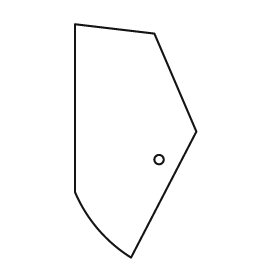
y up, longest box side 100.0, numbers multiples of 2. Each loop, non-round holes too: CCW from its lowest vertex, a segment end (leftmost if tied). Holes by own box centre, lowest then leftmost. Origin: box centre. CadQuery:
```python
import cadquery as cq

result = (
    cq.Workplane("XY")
    .moveTo(-2.0, -50.0)
    .lineTo(26.0, 4.0)
    .lineTo(8.0, 46.0)
    .lineTo(-26.0, 50.0)
    .lineTo(-26.0, -22.0)
    .threePointArc((-16.0, -38.0), (-2.0, -50.0))
    .close()
    .moveTo(10.0, -8.0)
    .circle(2.0)
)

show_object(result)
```